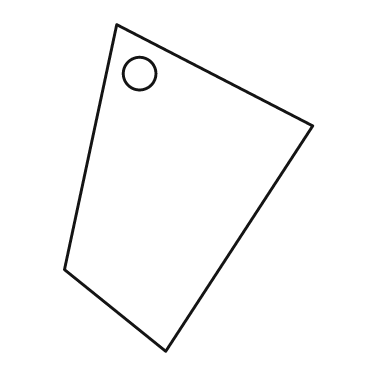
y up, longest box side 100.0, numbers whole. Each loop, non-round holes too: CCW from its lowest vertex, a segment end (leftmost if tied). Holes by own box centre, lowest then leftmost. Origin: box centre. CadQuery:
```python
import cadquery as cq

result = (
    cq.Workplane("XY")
    .moveTo(-7.0, -50.0)
    .lineTo(38.0, 19.0)
    .lineTo(-22.0, 50.0)
    .lineTo(-38.0, -25.0)
    .close()
    .moveTo(-15.0, 35.0)
    .circle(5.0)
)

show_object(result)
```